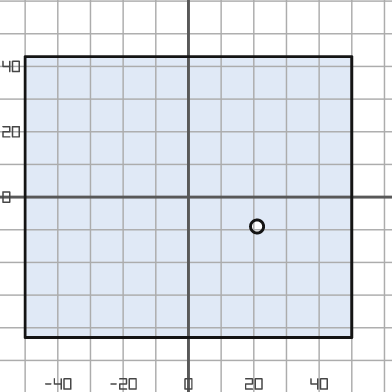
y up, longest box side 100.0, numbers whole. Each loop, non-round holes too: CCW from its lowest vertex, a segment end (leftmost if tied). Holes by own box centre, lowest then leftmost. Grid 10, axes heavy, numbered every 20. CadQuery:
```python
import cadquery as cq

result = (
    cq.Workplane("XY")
    .moveTo(-50.0, -43.0)
    .lineTo(50.0, -43.0)
    .lineTo(50.0, 43.0)
    .lineTo(-50.0, 43.0)
    .close()
    .moveTo(21.0, -9.0)
    .circle(2.0)
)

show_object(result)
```